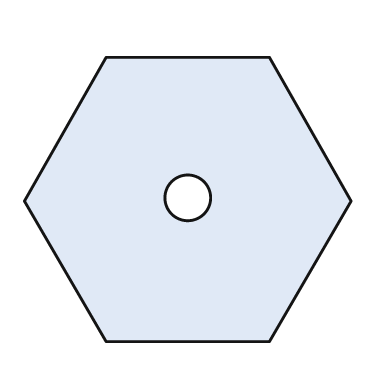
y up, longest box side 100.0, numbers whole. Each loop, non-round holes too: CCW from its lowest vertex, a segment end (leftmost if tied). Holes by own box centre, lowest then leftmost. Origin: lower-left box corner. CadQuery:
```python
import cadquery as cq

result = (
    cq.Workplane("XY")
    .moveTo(25.0, 0.0)
    .lineTo(75.0, 0.0)
    .lineTo(100.0, 43.0)
    .lineTo(75.0, 87.0)
    .lineTo(25.0, 87.0)
    .lineTo(0.0, 43.0)
    .close()
    .moveTo(50.0, 44.0)
    .circle(7.0)
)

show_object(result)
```